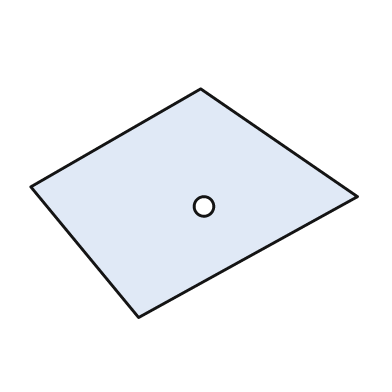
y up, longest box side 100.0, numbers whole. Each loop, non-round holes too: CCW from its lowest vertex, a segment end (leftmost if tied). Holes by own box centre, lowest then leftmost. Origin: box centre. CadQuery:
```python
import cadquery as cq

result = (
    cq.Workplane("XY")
    .moveTo(-17.0, -35.0)
    .lineTo(50.0, 2.0)
    .lineTo(2.0, 35.0)
    .lineTo(-50.0, 5.0)
    .close()
    .moveTo(3.0, -1.0)
    .circle(3.0)
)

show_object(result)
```